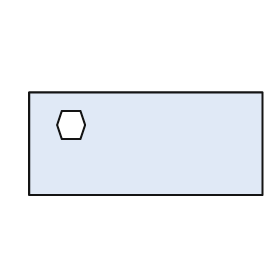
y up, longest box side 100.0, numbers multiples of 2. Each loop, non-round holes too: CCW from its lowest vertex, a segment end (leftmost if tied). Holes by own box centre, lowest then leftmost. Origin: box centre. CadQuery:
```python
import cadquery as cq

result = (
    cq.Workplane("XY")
    .moveTo(-50.0, -22.0)
    .lineTo(50.0, -22.0)
    .lineTo(50.0, 22.0)
    .lineTo(-50.0, 22.0)
    .close()
    .moveTo(-36.0, 2.0)
    .lineTo(-28.0, 2.0)
    .lineTo(-26.0, 8.0)
    .lineTo(-28.0, 14.0)
    .lineTo(-36.0, 14.0)
    .lineTo(-38.0, 8.0)
    .close()
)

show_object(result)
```